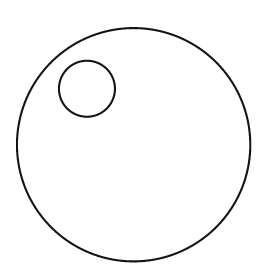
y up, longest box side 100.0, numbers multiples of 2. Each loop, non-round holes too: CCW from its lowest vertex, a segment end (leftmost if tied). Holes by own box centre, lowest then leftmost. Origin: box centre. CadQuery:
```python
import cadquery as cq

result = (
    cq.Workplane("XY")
    .moveTo(0.0, 0.0)
    .circle(50.0)
    .moveTo(-20.0, 24.0)
    .circle(12.0)
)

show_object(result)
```